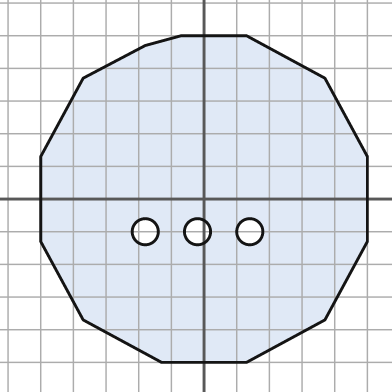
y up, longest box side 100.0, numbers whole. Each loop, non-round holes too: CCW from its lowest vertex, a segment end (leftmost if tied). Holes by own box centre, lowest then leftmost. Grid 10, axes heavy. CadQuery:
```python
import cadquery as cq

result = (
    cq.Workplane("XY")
    .moveTo(-13.0, -50.0)
    .lineTo(13.0, -50.0)
    .lineTo(37.0, -37.0)
    .lineTo(50.0, -13.0)
    .lineTo(50.0, 13.0)
    .lineTo(37.0, 37.0)
    .lineTo(13.0, 50.0)
    .lineTo(-7.0, 50.0)
    .lineTo(-18.0, 47.0)
    .lineTo(-37.0, 37.0)
    .lineTo(-50.0, 13.0)
    .lineTo(-50.0, -13.0)
    .lineTo(-37.0, -37.0)
    .close()
    .moveTo(-18.0, -10.0)
    .circle(4.0)
    .moveTo(-2.0, -10.0)
    .circle(4.0)
    .moveTo(14.0, -10.0)
    .circle(4.0)
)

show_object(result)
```